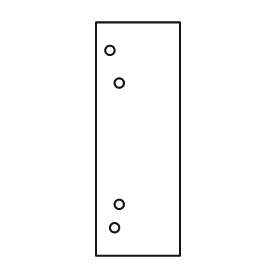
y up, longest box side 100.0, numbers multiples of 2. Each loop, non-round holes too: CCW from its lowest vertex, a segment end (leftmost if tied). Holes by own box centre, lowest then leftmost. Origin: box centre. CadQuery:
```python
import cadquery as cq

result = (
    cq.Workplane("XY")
    .moveTo(-18.0, -50.0)
    .lineTo(18.0, -50.0)
    .lineTo(18.0, 50.0)
    .lineTo(-18.0, 50.0)
    .close()
    .moveTo(-10.0, -38.0)
    .circle(2.0)
    .moveTo(-8.0, -28.0)
    .circle(2.0)
    .moveTo(-8.0, 24.0)
    .circle(2.0)
    .moveTo(-12.0, 38.0)
    .circle(2.0)
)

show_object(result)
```